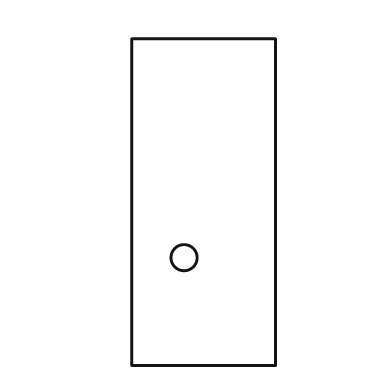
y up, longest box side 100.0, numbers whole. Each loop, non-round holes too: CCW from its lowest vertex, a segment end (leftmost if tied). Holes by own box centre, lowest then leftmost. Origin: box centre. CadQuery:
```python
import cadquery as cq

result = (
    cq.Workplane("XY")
    .moveTo(-22.0, -50.0)
    .lineTo(22.0, -50.0)
    .lineTo(22.0, 50.0)
    .lineTo(-22.0, 50.0)
    .close()
    .moveTo(-6.0, -17.0)
    .circle(4.0)
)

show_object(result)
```